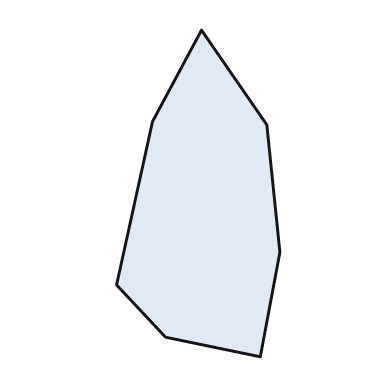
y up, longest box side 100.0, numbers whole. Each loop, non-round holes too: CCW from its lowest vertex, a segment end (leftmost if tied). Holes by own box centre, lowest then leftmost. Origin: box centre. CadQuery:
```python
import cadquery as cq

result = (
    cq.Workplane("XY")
    .moveTo(19.0, -50.0)
    .lineTo(25.0, -18.0)
    .lineTo(21.0, 21.0)
    .lineTo(1.0, 50.0)
    .lineTo(-14.0, 22.0)
    .lineTo(-25.0, -28.0)
    .lineTo(-10.0, -44.0)
    .close()
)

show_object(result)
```